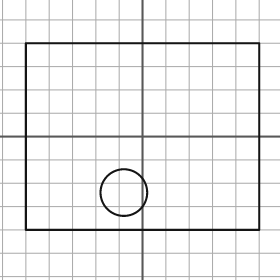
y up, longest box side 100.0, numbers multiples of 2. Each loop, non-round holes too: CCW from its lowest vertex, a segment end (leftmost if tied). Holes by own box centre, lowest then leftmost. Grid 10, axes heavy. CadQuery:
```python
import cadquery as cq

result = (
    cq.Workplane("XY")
    .moveTo(-50.0, -40.0)
    .lineTo(50.0, -40.0)
    .lineTo(50.0, 40.0)
    .lineTo(-50.0, 40.0)
    .close()
    .moveTo(-8.0, -24.0)
    .circle(10.0)
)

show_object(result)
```